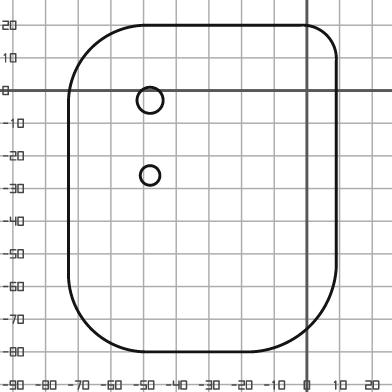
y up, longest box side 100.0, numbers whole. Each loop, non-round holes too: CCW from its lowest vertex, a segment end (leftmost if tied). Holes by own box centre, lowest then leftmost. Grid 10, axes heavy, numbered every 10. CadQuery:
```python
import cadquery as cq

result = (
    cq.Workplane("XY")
    .moveTo(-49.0, -80.0)
    .lineTo(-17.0, -80.0)
    .threePointArc((1.0, -72.0), (9.0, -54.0))
    .lineTo(9.0, 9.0)
    .threePointArc((6.0, 17.0), (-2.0, 20.0))
    .lineTo(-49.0, 20.0)
    .threePointArc((-66.0, 13.0), (-73.0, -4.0))
    .lineTo(-73.0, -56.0)
    .threePointArc((-66.0, -73.0), (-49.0, -80.0))
    .close()
    .moveTo(-48.0, -26.0)
    .circle(3.0)
    .moveTo(-48.0, -3.0)
    .circle(4.0)
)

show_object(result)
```